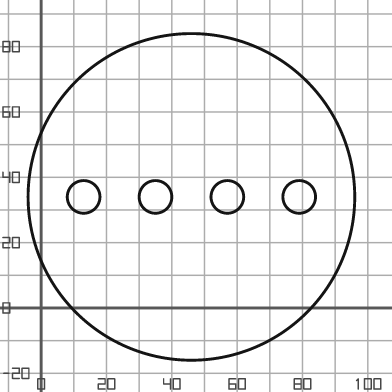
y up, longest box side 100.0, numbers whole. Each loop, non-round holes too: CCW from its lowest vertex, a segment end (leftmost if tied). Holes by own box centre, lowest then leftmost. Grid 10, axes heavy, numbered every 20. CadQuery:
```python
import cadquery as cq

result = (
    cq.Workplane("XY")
    .moveTo(46.0, 34.0)
    .circle(50.0)
    .moveTo(13.0, 34.0)
    .circle(5.0)
    .moveTo(35.0, 34.0)
    .circle(5.0)
    .moveTo(57.0, 34.0)
    .circle(5.0)
    .moveTo(79.0, 34.0)
    .circle(5.0)
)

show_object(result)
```